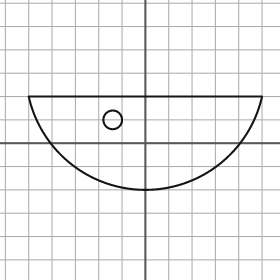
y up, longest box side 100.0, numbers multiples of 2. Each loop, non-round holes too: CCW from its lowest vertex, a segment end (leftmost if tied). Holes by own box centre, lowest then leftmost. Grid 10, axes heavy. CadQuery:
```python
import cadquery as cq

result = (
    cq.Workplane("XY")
    .moveTo(-50.0, 20.0)
    .threePointArc((0.0, -20.0), (50.0, 20.0))
    .close()
    .moveTo(-14.0, 10.0)
    .circle(4.0)
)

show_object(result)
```